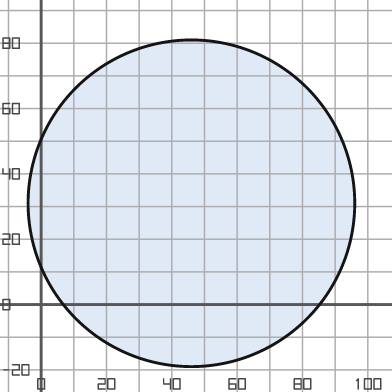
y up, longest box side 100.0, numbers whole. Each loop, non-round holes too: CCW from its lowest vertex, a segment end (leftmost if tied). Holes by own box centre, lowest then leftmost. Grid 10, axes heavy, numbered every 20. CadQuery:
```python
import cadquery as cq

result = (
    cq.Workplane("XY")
    .moveTo(46.0, 31.0)
    .circle(50.0)
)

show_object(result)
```